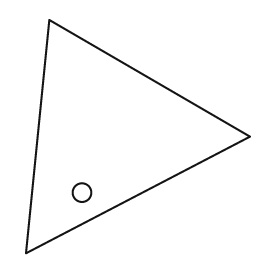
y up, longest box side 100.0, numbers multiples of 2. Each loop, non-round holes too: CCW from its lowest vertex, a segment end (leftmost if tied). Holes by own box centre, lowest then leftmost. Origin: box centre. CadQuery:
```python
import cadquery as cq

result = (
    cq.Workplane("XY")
    .moveTo(-48.0, -50.0)
    .lineTo(48.0, 0.0)
    .lineTo(-38.0, 50.0)
    .close()
    .moveTo(-24.0, -24.0)
    .circle(4.0)
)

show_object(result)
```